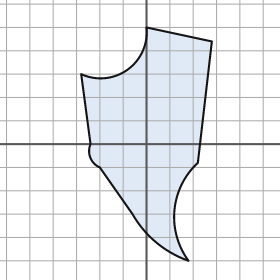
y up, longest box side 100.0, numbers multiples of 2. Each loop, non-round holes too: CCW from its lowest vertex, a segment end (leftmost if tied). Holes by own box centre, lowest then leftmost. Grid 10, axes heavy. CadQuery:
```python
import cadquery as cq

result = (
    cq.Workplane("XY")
    .moveTo(18.0, -50.0)
    .threePointArc((12.0, -28.0), (22.0, -8.0))
    .lineTo(28.0, 44.0)
    .lineTo(0.0, 50.0)
    .threePointArc((-8.0, 32.0), (-28.0, 30.0))
    .lineTo(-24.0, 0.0)
    .threePointArc((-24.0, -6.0), (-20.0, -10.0))
    .lineTo(-6.0, -30.0)
    .threePointArc((4.0, -42.0), (18.0, -50.0))
    .close()
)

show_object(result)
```